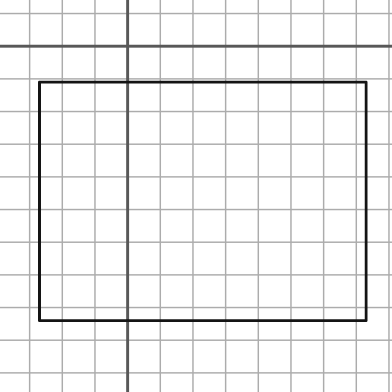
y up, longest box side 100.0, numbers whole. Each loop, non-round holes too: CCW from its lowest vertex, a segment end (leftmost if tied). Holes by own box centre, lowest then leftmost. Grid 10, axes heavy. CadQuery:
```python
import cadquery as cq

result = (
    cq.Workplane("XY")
    .moveTo(-27.0, -84.0)
    .lineTo(73.0, -84.0)
    .lineTo(73.0, -11.0)
    .lineTo(-27.0, -11.0)
    .close()
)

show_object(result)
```